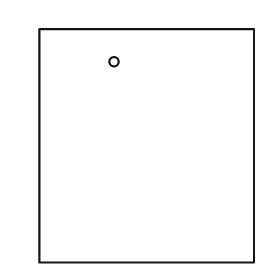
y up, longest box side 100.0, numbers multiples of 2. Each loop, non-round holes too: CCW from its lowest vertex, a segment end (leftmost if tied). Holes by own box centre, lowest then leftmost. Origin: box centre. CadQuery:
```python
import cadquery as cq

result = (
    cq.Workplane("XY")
    .moveTo(-46.0, -50.0)
    .lineTo(46.0, -50.0)
    .lineTo(46.0, 50.0)
    .lineTo(-46.0, 50.0)
    .close()
    .moveTo(-14.0, 36.0)
    .circle(2.0)
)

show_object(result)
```